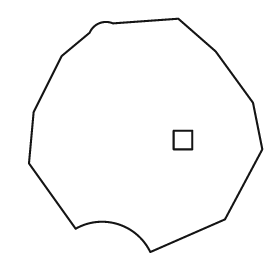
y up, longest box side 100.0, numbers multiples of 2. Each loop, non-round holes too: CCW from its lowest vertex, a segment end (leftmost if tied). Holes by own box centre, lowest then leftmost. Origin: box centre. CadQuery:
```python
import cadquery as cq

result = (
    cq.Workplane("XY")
    .moveTo(2.0, -50.0)
    .lineTo(34.0, -36.0)
    .lineTo(50.0, -6.0)
    .lineTo(46.0, 14.0)
    .lineTo(30.0, 36.0)
    .lineTo(14.0, 50.0)
    .lineTo(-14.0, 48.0)
    .threePointArc((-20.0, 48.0), (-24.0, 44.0))
    .lineTo(-36.0, 34.0)
    .lineTo(-48.0, 10.0)
    .lineTo(-50.0, -12.0)
    .lineTo(-30.0, -40.0)
    .threePointArc((-12.0, -38.0), (2.0, -50.0))
    .close()
    .moveTo(12.0, -6.0)
    .lineTo(20.0, -6.0)
    .lineTo(20.0, 2.0)
    .lineTo(12.0, 2.0)
    .close()
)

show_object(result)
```